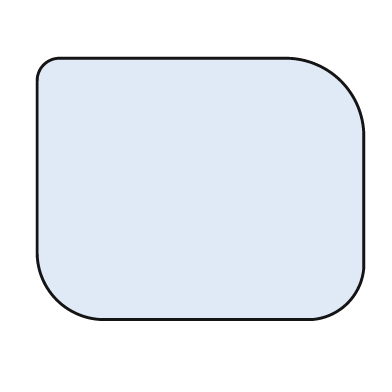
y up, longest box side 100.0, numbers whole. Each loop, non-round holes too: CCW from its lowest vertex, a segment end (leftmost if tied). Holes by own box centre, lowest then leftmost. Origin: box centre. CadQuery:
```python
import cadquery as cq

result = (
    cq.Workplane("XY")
    .moveTo(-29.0, -40.0)
    .lineTo(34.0, -40.0)
    .threePointArc((45.0, -35.0), (50.0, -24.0))
    .lineTo(50.0, 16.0)
    .threePointArc((43.0, 33.0), (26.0, 40.0))
    .lineTo(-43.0, 40.0)
    .threePointArc((-48.0, 38.0), (-50.0, 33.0))
    .lineTo(-50.0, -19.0)
    .threePointArc((-44.0, -34.0), (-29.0, -40.0))
    .close()
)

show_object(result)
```